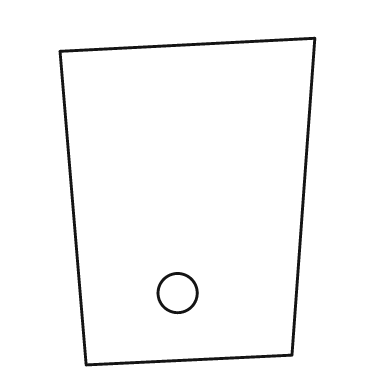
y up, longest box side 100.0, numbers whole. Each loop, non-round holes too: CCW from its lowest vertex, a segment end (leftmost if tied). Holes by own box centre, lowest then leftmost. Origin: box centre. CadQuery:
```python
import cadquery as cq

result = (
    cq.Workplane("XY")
    .moveTo(-31.0, -50.0)
    .lineTo(32.0, -47.0)
    .lineTo(39.0, 50.0)
    .lineTo(-39.0, 46.0)
    .close()
    .moveTo(-3.0, -28.0)
    .circle(6.0)
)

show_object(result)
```